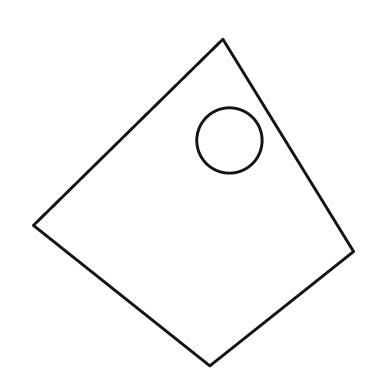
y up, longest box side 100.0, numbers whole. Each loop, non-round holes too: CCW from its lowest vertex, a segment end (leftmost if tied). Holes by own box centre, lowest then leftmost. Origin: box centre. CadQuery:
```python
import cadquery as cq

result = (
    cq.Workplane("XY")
    .moveTo(5.0, -50.0)
    .lineTo(49.0, -15.0)
    .lineTo(9.0, 50.0)
    .lineTo(-49.0, -7.0)
    .close()
    .moveTo(11.0, 19.0)
    .circle(10.0)
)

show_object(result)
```